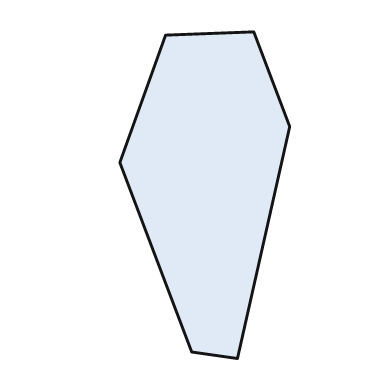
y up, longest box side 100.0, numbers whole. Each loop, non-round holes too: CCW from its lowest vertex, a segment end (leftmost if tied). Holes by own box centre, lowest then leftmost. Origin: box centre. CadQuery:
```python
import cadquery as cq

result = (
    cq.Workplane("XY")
    .moveTo(10.0, -50.0)
    .lineTo(26.0, 21.0)
    .lineTo(15.0, 50.0)
    .lineTo(-12.0, 49.0)
    .lineTo(-26.0, 10.0)
    .lineTo(-4.0, -48.0)
    .close()
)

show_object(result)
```